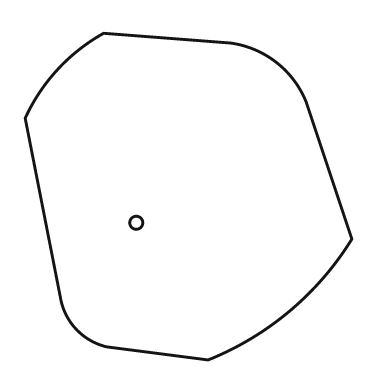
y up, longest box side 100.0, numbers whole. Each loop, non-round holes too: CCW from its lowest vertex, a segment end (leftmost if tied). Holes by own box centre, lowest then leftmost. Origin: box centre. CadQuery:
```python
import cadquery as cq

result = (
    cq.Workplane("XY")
    .moveTo(6.0, -50.0)
    .threePointArc((31.0, -35.0), (50.0, -13.0))
    .lineTo(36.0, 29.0)
    .threePointArc((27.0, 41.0), (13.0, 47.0))
    .lineTo(-26.0, 50.0)
    .threePointArc((-40.0, 39.0), (-50.0, 24.0))
    .lineTo(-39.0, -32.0)
    .threePointArc((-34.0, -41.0), (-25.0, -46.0))
    .close()
    .moveTo(-16.0, -8.0)
    .circle(2.0)
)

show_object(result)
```